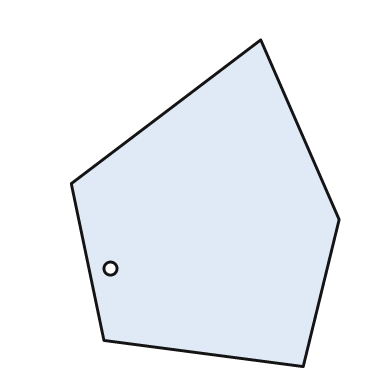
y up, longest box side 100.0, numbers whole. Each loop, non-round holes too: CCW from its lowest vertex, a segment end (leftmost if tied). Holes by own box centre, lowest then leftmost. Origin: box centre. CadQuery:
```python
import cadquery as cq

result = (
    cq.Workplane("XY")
    .moveTo(30.0, -50.0)
    .lineTo(41.0, -5.0)
    .lineTo(17.0, 50.0)
    .lineTo(-41.0, 6.0)
    .lineTo(-31.0, -42.0)
    .close()
    .moveTo(-29.0, -20.0)
    .circle(2.0)
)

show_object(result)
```